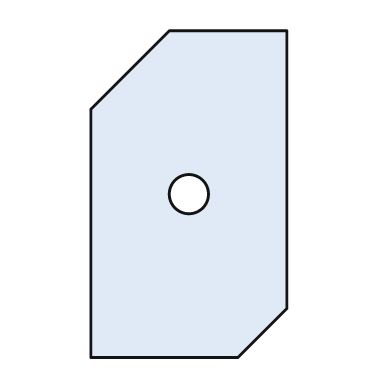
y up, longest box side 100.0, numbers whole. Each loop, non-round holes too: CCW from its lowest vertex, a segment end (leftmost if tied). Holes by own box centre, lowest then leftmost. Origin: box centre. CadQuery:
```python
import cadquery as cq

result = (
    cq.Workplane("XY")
    .moveTo(-30.0, -50.0)
    .lineTo(15.0, -50.0)
    .lineTo(30.0, -35.0)
    .lineTo(30.0, 50.0)
    .lineTo(-6.0, 50.0)
    .lineTo(-30.0, 26.0)
    .close()
    .moveTo(0.0, 0.0)
    .circle(6.0)
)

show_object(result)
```